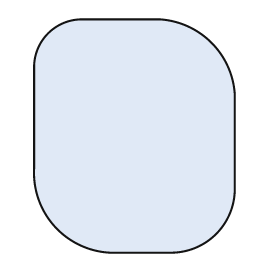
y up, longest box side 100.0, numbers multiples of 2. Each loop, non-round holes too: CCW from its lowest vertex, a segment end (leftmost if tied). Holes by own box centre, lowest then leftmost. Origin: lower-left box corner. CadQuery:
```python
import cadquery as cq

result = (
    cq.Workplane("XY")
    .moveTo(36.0, 0.0)
    .lineTo(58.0, 0.0)
    .threePointArc((78.0, 8.0), (86.0, 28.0))
    .lineTo(86.0, 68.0)
    .threePointArc((76.0, 90.0), (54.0, 100.0))
    .lineTo(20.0, 100.0)
    .threePointArc((6.0, 94.0), (0.0, 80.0))
    .lineTo(0.0, 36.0)
    .threePointArc((10.0, 10.0), (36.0, 0.0))
    .close()
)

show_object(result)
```